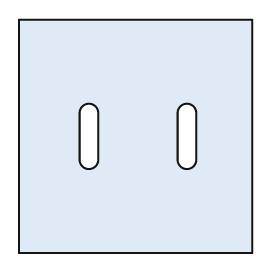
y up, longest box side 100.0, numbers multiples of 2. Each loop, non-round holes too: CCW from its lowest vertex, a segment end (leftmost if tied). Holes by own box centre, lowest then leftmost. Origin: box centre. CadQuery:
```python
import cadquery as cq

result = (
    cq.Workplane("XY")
    .moveTo(-50.0, -50.0)
    .lineTo(50.0, -50.0)
    .lineTo(50.0, 50.0)
    .lineTo(-50.0, 50.0)
    .close()
    .moveTo(-24.0, -10.0)
    .threePointArc((-20.0, -14.0), (-16.0, -10.0))
    .lineTo(-16.0, 10.0)
    .threePointArc((-20.0, 14.0), (-24.0, 10.0))
    .close()
    .moveTo(18.0, -10.0)
    .threePointArc((22.0, -14.0), (26.0, -10.0))
    .lineTo(26.0, 10.0)
    .threePointArc((22.0, 14.0), (18.0, 10.0))
    .close()
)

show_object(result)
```